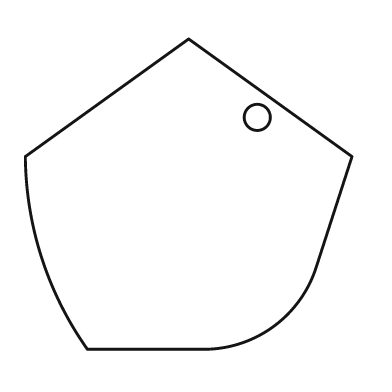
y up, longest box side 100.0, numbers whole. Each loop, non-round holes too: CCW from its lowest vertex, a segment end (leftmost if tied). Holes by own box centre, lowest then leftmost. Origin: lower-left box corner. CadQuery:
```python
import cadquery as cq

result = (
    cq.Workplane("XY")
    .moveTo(19.0, 0.0)
    .lineTo(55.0, 0.0)
    .threePointArc((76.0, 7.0), (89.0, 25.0))
    .lineTo(100.0, 59.0)
    .lineTo(50.0, 95.0)
    .lineTo(0.0, 59.0)
    .threePointArc((5.0, 28.0), (19.0, 0.0))
    .close()
    .moveTo(71.0, 71.0)
    .circle(4.0)
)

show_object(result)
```